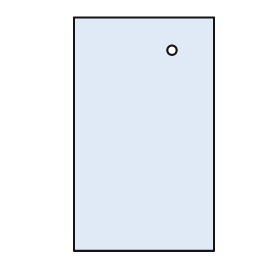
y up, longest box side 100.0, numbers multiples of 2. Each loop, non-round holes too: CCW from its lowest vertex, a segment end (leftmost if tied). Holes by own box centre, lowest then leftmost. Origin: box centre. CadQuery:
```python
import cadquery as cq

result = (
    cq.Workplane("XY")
    .moveTo(-30.0, -50.0)
    .lineTo(30.0, -50.0)
    .lineTo(30.0, 50.0)
    .lineTo(-30.0, 50.0)
    .close()
    .moveTo(12.0, 36.0)
    .circle(2.0)
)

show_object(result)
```